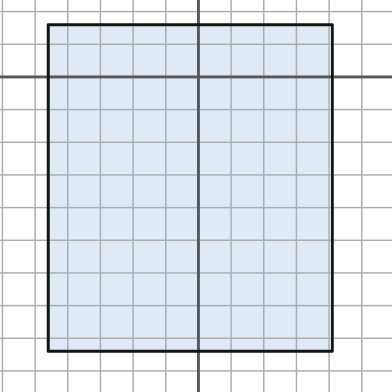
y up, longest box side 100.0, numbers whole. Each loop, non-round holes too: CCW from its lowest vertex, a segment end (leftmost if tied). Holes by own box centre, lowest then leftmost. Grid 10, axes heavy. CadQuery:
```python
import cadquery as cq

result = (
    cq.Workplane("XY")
    .moveTo(-46.0, -84.0)
    .lineTo(41.0, -84.0)
    .lineTo(41.0, 16.0)
    .lineTo(-46.0, 16.0)
    .close()
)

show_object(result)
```